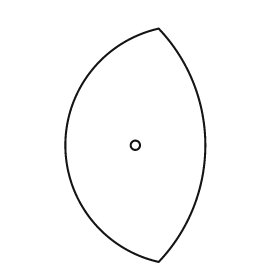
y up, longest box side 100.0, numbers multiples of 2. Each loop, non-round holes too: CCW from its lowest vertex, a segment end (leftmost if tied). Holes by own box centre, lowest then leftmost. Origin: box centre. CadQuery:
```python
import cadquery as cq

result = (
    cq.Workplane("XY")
    .moveTo(10.0, -50.0)
    .threePointArc((30.0, 0.0), (10.0, 50.0))
    .threePointArc((-30.0, 0.0), (10.0, -50.0))
    .close()
    .moveTo(0.0, 0.0)
    .circle(2.0)
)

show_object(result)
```